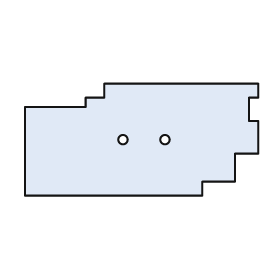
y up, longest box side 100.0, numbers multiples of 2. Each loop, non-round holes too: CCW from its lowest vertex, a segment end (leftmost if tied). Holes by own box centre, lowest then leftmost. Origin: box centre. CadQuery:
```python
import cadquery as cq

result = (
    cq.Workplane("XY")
    .moveTo(-50.0, -24.0)
    .lineTo(26.0, -24.0)
    .lineTo(26.0, -18.0)
    .lineTo(40.0, -18.0)
    .lineTo(40.0, -6.0)
    .lineTo(50.0, -6.0)
    .lineTo(50.0, 8.0)
    .lineTo(46.0, 8.0)
    .lineTo(46.0, 18.0)
    .lineTo(50.0, 18.0)
    .lineTo(50.0, 24.0)
    .lineTo(-16.0, 24.0)
    .lineTo(-16.0, 18.0)
    .lineTo(-24.0, 18.0)
    .lineTo(-24.0, 14.0)
    .lineTo(-50.0, 14.0)
    .close()
    .moveTo(-8.0, 0.0)
    .circle(2.0)
    .moveTo(10.0, 0.0)
    .circle(2.0)
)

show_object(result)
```